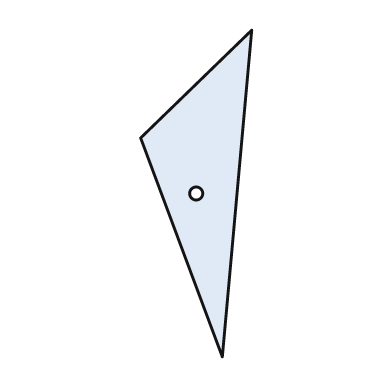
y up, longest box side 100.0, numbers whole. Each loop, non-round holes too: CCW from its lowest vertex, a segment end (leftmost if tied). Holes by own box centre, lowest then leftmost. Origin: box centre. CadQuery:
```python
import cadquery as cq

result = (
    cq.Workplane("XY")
    .moveTo(8.0, -50.0)
    .lineTo(17.0, 50.0)
    .lineTo(-17.0, 17.0)
    .close()
    .moveTo(0.0, 0.0)
    .circle(2.0)
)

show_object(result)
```